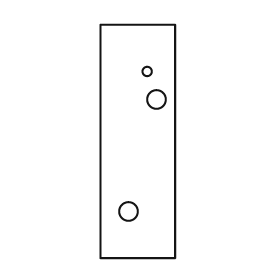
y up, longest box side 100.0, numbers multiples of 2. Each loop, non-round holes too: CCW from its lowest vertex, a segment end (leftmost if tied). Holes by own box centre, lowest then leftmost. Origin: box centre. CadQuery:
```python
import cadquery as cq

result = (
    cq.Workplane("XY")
    .moveTo(-16.0, -50.0)
    .lineTo(16.0, -50.0)
    .lineTo(16.0, 50.0)
    .lineTo(-16.0, 50.0)
    .close()
    .moveTo(-4.0, -30.0)
    .circle(4.0)
    .moveTo(8.0, 18.0)
    .circle(4.0)
    .moveTo(4.0, 30.0)
    .circle(2.0)
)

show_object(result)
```